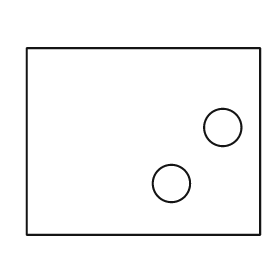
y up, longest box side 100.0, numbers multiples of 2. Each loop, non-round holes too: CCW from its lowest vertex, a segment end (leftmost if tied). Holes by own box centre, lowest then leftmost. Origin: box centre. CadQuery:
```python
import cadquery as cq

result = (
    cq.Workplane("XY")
    .moveTo(-50.0, -40.0)
    .lineTo(50.0, -40.0)
    .lineTo(50.0, 40.0)
    .lineTo(-50.0, 40.0)
    .close()
    .moveTo(12.0, -18.0)
    .circle(8.0)
    .moveTo(34.0, 6.0)
    .circle(8.0)
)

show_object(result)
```